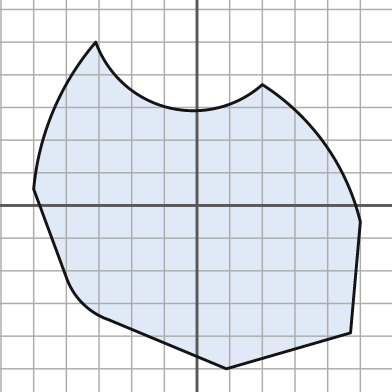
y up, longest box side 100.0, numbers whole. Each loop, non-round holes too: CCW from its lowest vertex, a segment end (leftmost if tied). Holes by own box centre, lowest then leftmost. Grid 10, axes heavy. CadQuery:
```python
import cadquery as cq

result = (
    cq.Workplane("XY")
    .moveTo(9.0, -50.0)
    .lineTo(47.0, -39.0)
    .lineTo(50.0, -5.0)
    .threePointArc((39.0, 19.0), (20.0, 37.0))
    .threePointArc((-9.0, 30.0), (-31.0, 50.0))
    .threePointArc((-44.0, 29.0), (-50.0, 5.0))
    .lineTo(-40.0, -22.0)
    .threePointArc((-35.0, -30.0), (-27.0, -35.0))
    .close()
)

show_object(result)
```